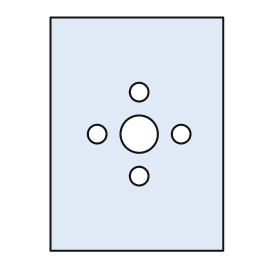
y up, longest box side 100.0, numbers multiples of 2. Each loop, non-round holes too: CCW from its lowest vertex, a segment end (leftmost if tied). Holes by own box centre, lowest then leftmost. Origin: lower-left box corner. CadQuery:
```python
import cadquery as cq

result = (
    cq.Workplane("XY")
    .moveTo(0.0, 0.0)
    .lineTo(74.0, 0.0)
    .lineTo(74.0, 100.0)
    .lineTo(0.0, 100.0)
    .close()
    .moveTo(38.0, 32.0)
    .circle(4.0)
    .moveTo(20.0, 50.0)
    .circle(4.0)
    .moveTo(38.0, 50.0)
    .circle(8.0)
    .moveTo(56.0, 50.0)
    .circle(4.0)
    .moveTo(38.0, 68.0)
    .circle(4.0)
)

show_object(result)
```